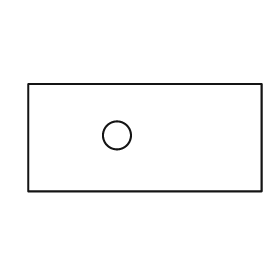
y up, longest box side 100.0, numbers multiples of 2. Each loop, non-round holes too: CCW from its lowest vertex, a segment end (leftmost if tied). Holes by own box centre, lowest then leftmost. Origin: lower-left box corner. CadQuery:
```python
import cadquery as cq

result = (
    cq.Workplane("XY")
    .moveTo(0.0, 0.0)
    .lineTo(100.0, 0.0)
    .lineTo(100.0, 46.0)
    .lineTo(0.0, 46.0)
    .close()
    .moveTo(38.0, 24.0)
    .circle(6.0)
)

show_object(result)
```